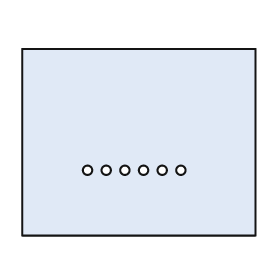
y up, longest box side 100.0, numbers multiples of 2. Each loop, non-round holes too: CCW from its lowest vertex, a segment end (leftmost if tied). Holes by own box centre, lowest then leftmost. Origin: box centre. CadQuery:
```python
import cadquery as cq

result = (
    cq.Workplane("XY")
    .moveTo(-50.0, -40.0)
    .lineTo(50.0, -40.0)
    .lineTo(50.0, 40.0)
    .lineTo(-50.0, 40.0)
    .close()
    .moveTo(-22.0, -12.0)
    .circle(2.0)
    .moveTo(-14.0, -12.0)
    .circle(2.0)
    .moveTo(-6.0, -12.0)
    .circle(2.0)
    .moveTo(2.0, -12.0)
    .circle(2.0)
    .moveTo(10.0, -12.0)
    .circle(2.0)
    .moveTo(18.0, -12.0)
    .circle(2.0)
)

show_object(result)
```